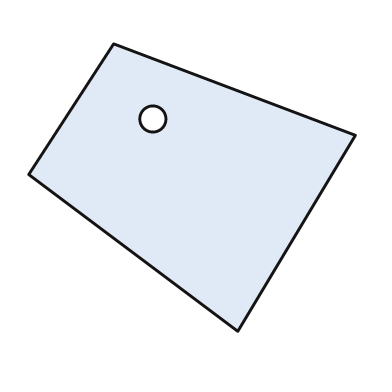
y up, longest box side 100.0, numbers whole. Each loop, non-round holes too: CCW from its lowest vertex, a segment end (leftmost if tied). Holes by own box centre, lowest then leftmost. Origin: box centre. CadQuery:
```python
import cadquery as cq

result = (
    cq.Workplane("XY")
    .moveTo(14.0, -44.0)
    .lineTo(50.0, 16.0)
    .lineTo(-24.0, 44.0)
    .lineTo(-50.0, 4.0)
    .close()
    .moveTo(-12.0, 21.0)
    .circle(4.0)
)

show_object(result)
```